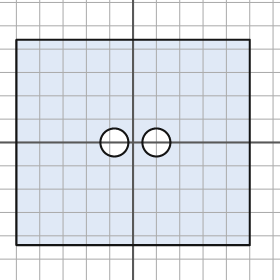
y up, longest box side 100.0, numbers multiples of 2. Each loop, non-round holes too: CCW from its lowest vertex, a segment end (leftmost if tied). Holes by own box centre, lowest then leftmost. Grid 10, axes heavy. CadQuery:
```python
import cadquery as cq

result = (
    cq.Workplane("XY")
    .moveTo(-50.0, -44.0)
    .lineTo(50.0, -44.0)
    .lineTo(50.0, 44.0)
    .lineTo(-50.0, 44.0)
    .close()
    .moveTo(-8.0, 0.0)
    .circle(6.0)
    .moveTo(10.0, 0.0)
    .circle(6.0)
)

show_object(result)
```